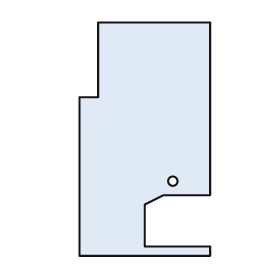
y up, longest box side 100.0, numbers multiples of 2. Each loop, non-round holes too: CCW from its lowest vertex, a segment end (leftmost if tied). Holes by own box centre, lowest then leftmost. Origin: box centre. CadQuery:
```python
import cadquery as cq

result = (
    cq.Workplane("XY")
    .moveTo(-28.0, -50.0)
    .lineTo(28.0, -50.0)
    .lineTo(28.0, -46.0)
    .lineTo(0.0, -46.0)
    .lineTo(0.0, -28.0)
    .lineTo(8.0, -24.0)
    .lineTo(28.0, -24.0)
    .lineTo(28.0, 50.0)
    .lineTo(-20.0, 50.0)
    .lineTo(-20.0, 18.0)
    .lineTo(-28.0, 18.0)
    .close()
    .moveTo(12.0, -18.0)
    .circle(2.0)
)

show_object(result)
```